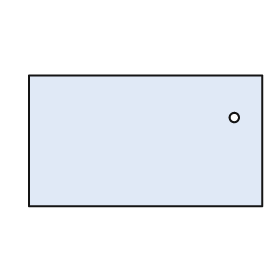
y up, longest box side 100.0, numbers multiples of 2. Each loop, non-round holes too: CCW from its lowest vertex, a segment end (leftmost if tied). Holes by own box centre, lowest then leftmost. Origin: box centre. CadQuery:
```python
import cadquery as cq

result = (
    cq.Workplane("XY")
    .moveTo(-50.0, -28.0)
    .lineTo(50.0, -28.0)
    .lineTo(50.0, 28.0)
    .lineTo(-50.0, 28.0)
    .close()
    .moveTo(38.0, 10.0)
    .circle(2.0)
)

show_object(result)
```